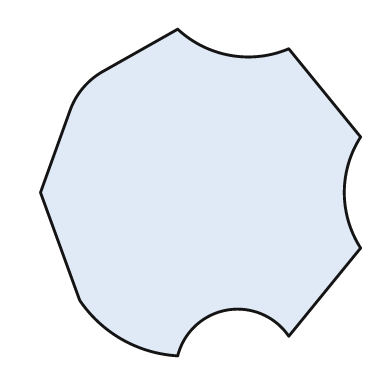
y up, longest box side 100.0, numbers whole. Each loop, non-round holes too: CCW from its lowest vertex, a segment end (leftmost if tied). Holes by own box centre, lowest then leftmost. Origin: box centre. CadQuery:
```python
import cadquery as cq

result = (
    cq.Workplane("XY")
    .moveTo(-7.0, -50.0)
    .threePointArc((8.0, -36.0), (27.0, -44.0))
    .lineTo(49.0, -17.0)
    .threePointArc((44.0, 0.0), (49.0, 17.0))
    .lineTo(27.0, 44.0)
    .threePointArc((9.0, 42.0), (-7.0, 50.0))
    .lineTo(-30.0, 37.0)
    .threePointArc((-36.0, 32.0), (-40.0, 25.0))
    .lineTo(-49.0, 0.0)
    .lineTo(-37.0, -33.0)
    .threePointArc((-24.0, -45.0), (-7.0, -50.0))
    .close()
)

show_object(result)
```